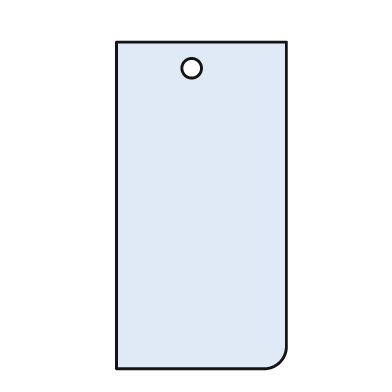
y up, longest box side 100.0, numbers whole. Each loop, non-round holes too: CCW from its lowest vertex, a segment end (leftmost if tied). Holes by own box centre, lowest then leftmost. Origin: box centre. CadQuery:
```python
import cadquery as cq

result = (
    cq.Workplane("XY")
    .moveTo(-26.0, -50.0)
    .lineTo(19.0, -50.0)
    .threePointArc((24.0, -48.0), (26.0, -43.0))
    .lineTo(26.0, 50.0)
    .lineTo(-26.0, 50.0)
    .close()
    .moveTo(-3.0, 42.0)
    .circle(3.0)
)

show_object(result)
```